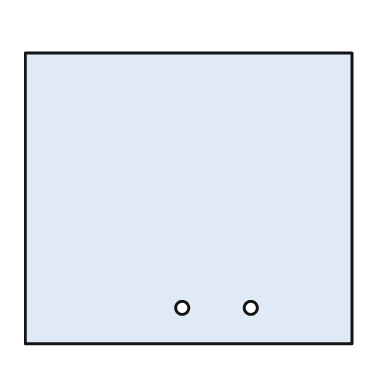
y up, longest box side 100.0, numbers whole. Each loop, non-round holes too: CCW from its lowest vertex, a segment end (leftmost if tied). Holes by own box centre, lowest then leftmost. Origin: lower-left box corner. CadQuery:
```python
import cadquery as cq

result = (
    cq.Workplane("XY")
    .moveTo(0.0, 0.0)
    .lineTo(100.0, 0.0)
    .lineTo(100.0, 89.0)
    .lineTo(0.0, 89.0)
    .close()
    .moveTo(48.0, 11.0)
    .circle(2.0)
    .moveTo(69.0, 11.0)
    .circle(2.0)
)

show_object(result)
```